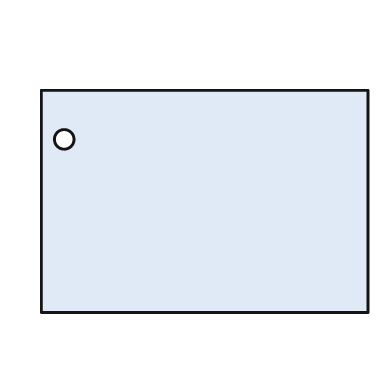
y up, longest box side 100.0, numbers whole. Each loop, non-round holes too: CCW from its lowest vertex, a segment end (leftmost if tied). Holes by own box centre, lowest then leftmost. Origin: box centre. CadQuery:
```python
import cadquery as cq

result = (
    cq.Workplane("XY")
    .moveTo(-50.0, -34.0)
    .lineTo(50.0, -34.0)
    .lineTo(50.0, 34.0)
    .lineTo(-50.0, 34.0)
    .close()
    .moveTo(-43.0, 19.0)
    .circle(3.0)
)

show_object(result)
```